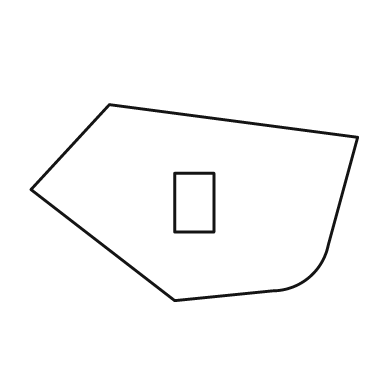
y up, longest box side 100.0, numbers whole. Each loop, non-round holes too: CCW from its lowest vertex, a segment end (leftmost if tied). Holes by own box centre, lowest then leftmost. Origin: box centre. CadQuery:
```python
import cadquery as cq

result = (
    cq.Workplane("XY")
    .moveTo(-6.0, -30.0)
    .lineTo(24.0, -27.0)
    .threePointArc((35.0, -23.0), (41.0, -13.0))
    .lineTo(50.0, 20.0)
    .lineTo(-26.0, 30.0)
    .lineTo(-50.0, 4.0)
    .close()
    .moveTo(-6.0, -9.0)
    .lineTo(6.0, -9.0)
    .lineTo(6.0, 9.0)
    .lineTo(-6.0, 9.0)
    .close()
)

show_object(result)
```